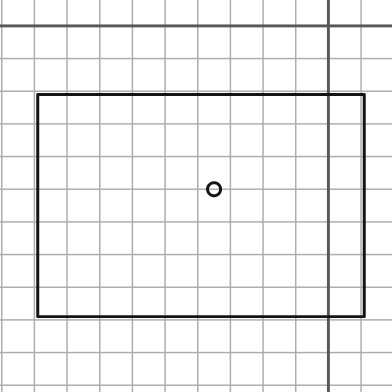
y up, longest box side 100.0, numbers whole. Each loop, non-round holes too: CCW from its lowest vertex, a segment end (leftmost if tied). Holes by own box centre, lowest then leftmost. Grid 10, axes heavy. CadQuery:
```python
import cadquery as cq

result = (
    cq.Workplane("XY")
    .moveTo(-89.0, -89.0)
    .lineTo(11.0, -89.0)
    .lineTo(11.0, -21.0)
    .lineTo(-89.0, -21.0)
    .close()
    .moveTo(-35.0, -50.0)
    .circle(2.0)
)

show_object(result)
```